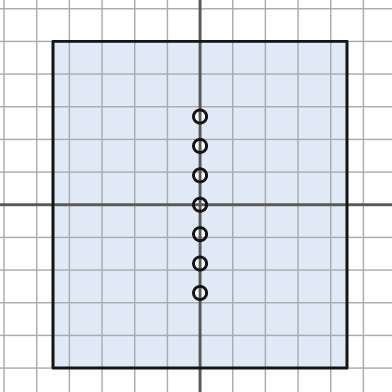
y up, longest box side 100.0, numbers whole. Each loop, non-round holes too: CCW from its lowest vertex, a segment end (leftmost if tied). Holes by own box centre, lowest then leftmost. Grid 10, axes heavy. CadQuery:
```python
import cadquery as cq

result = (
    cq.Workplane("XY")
    .moveTo(-45.0, -50.0)
    .lineTo(45.0, -50.0)
    .lineTo(45.0, 50.0)
    .lineTo(-45.0, 50.0)
    .close()
    .moveTo(0.0, -27.0)
    .circle(2.0)
    .moveTo(0.0, -18.0)
    .circle(2.0)
    .moveTo(0.0, -9.0)
    .circle(2.0)
    .moveTo(0.0, 0.0)
    .circle(2.0)
    .moveTo(0.0, 9.0)
    .circle(2.0)
    .moveTo(0.0, 18.0)
    .circle(2.0)
    .moveTo(0.0, 27.0)
    .circle(2.0)
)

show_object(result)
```